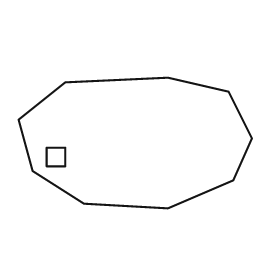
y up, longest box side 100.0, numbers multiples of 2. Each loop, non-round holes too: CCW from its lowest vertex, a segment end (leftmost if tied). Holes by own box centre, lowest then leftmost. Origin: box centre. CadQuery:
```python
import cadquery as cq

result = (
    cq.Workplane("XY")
    .moveTo(14.0, -28.0)
    .lineTo(42.0, -16.0)
    .lineTo(50.0, 2.0)
    .lineTo(40.0, 22.0)
    .lineTo(14.0, 28.0)
    .lineTo(-30.0, 26.0)
    .lineTo(-50.0, 10.0)
    .lineTo(-44.0, -12.0)
    .lineTo(-22.0, -26.0)
    .close()
    .moveTo(-38.0, -10.0)
    .lineTo(-30.0, -10.0)
    .lineTo(-30.0, -2.0)
    .lineTo(-38.0, -2.0)
    .close()
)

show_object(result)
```